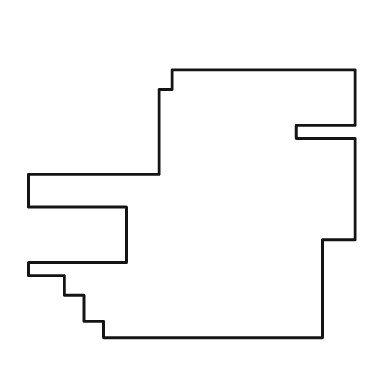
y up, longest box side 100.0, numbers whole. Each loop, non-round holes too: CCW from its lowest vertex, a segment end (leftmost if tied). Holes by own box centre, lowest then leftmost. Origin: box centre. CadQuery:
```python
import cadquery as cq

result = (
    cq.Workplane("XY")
    .moveTo(-27.0, -41.0)
    .lineTo(40.0, -41.0)
    .lineTo(40.0, -11.0)
    .lineTo(50.0, -11.0)
    .lineTo(50.0, 20.0)
    .lineTo(32.0, 20.0)
    .lineTo(32.0, 24.0)
    .lineTo(50.0, 24.0)
    .lineTo(50.0, 41.0)
    .lineTo(-6.0, 41.0)
    .lineTo(-6.0, 35.0)
    .lineTo(-10.0, 35.0)
    .lineTo(-10.0, 9.0)
    .lineTo(-50.0, 9.0)
    .lineTo(-50.0, -1.0)
    .lineTo(-20.0, -1.0)
    .lineTo(-20.0, -18.0)
    .lineTo(-50.0, -18.0)
    .lineTo(-50.0, -22.0)
    .lineTo(-39.0, -22.0)
    .lineTo(-39.0, -28.0)
    .lineTo(-33.0, -28.0)
    .lineTo(-33.0, -36.0)
    .lineTo(-27.0, -36.0)
    .close()
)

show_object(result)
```